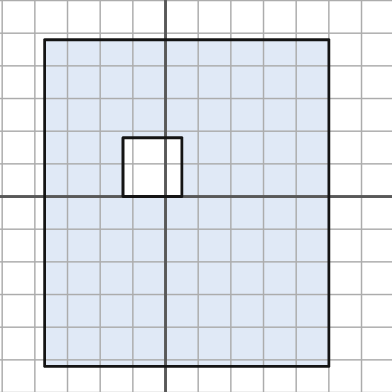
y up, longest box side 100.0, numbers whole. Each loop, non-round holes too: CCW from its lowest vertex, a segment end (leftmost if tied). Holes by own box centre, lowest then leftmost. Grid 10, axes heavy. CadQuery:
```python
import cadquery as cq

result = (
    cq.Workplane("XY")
    .moveTo(-37.0, -52.0)
    .lineTo(50.0, -52.0)
    .lineTo(50.0, 48.0)
    .lineTo(-37.0, 48.0)
    .close()
    .moveTo(-13.0, 0.0)
    .lineTo(5.0, 0.0)
    .lineTo(5.0, 18.0)
    .lineTo(-13.0, 18.0)
    .close()
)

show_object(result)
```